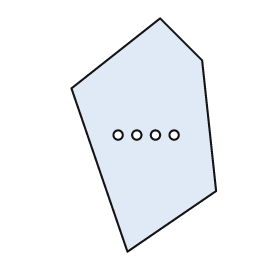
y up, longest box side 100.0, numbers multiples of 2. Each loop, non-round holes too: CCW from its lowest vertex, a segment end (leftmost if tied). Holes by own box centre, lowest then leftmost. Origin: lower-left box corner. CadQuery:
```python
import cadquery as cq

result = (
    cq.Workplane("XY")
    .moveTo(24.0, 0.0)
    .lineTo(62.0, 26.0)
    .lineTo(56.0, 82.0)
    .lineTo(38.0, 100.0)
    .lineTo(0.0, 70.0)
    .close()
    .moveTo(20.0, 50.0)
    .circle(2.0)
    .moveTo(28.0, 50.0)
    .circle(2.0)
    .moveTo(36.0, 50.0)
    .circle(2.0)
    .moveTo(44.0, 50.0)
    .circle(2.0)
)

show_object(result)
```